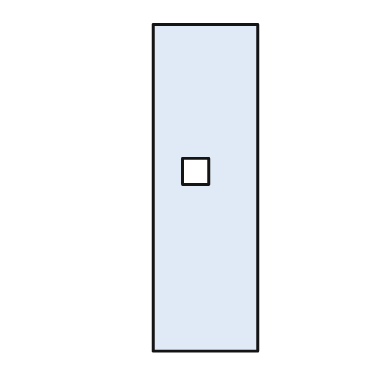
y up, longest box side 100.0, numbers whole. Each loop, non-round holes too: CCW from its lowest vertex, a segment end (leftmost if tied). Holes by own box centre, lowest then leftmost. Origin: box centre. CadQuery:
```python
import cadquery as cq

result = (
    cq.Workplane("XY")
    .moveTo(-16.0, -50.0)
    .lineTo(16.0, -50.0)
    .lineTo(16.0, 50.0)
    .lineTo(-16.0, 50.0)
    .close()
    .moveTo(-7.0, 1.0)
    .lineTo(1.0, 1.0)
    .lineTo(1.0, 9.0)
    .lineTo(-7.0, 9.0)
    .close()
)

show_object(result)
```